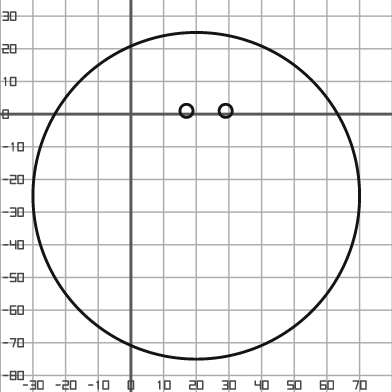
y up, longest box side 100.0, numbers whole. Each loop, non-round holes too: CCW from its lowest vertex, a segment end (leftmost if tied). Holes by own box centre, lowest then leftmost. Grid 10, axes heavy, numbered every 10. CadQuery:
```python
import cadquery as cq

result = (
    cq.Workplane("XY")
    .moveTo(20.0, -25.0)
    .circle(50.0)
    .moveTo(17.0, 1.0)
    .circle(2.0)
    .moveTo(29.0, 1.0)
    .circle(2.0)
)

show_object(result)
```